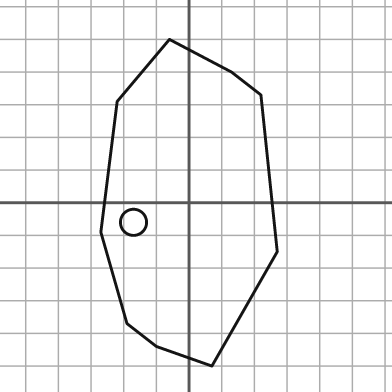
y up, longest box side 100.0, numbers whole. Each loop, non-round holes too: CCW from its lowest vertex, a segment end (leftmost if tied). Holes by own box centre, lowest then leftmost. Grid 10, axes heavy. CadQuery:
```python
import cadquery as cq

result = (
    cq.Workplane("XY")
    .moveTo(7.0, -50.0)
    .lineTo(27.0, -15.0)
    .lineTo(22.0, 33.0)
    .lineTo(13.0, 40.0)
    .lineTo(-6.0, 50.0)
    .lineTo(-22.0, 31.0)
    .lineTo(-27.0, -9.0)
    .lineTo(-19.0, -37.0)
    .lineTo(-10.0, -44.0)
    .close()
    .moveTo(-17.0, -6.0)
    .circle(4.0)
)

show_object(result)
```